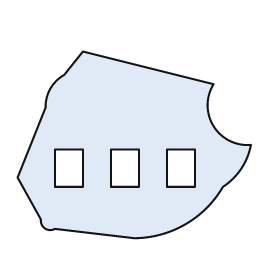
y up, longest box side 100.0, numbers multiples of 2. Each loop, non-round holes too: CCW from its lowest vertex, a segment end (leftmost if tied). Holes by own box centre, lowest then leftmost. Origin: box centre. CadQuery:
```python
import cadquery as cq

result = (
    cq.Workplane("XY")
    .moveTo(0.0, -40.0)
    .threePointArc((22.0, -34.0), (38.0, -18.0))
    .threePointArc((46.0, -10.0), (50.0, 0.0))
    .threePointArc((34.0, 8.0), (34.0, 26.0))
    .lineTo(-22.0, 40.0)
    .lineTo(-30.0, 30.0)
    .threePointArc((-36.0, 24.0), (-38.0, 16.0))
    .lineTo(-50.0, -14.0)
    .lineTo(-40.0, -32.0)
    .threePointArc((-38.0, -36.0), (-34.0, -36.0))
    .close()
    .moveTo(-34.0, -18.0)
    .lineTo(-22.0, -18.0)
    .lineTo(-22.0, -2.0)
    .lineTo(-34.0, -2.0)
    .close()
    .moveTo(-10.0, -18.0)
    .lineTo(2.0, -18.0)
    .lineTo(2.0, -2.0)
    .lineTo(-10.0, -2.0)
    .close()
    .moveTo(14.0, -18.0)
    .lineTo(26.0, -18.0)
    .lineTo(26.0, -2.0)
    .lineTo(14.0, -2.0)
    .close()
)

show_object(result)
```